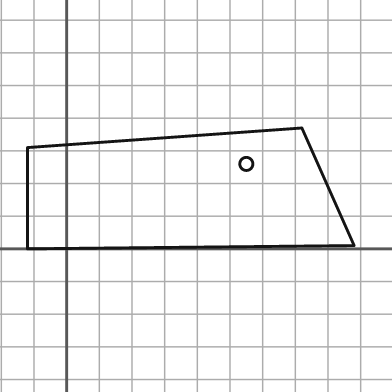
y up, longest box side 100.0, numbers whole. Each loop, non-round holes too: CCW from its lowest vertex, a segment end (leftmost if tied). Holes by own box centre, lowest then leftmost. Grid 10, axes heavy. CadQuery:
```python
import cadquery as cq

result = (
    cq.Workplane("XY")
    .moveTo(-12.0, 0.0)
    .lineTo(88.0, 1.0)
    .lineTo(72.0, 37.0)
    .lineTo(-12.0, 31.0)
    .close()
    .moveTo(55.0, 26.0)
    .circle(2.0)
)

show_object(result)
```